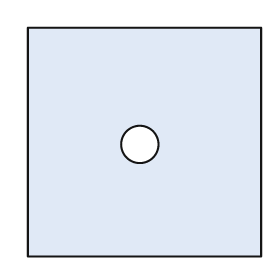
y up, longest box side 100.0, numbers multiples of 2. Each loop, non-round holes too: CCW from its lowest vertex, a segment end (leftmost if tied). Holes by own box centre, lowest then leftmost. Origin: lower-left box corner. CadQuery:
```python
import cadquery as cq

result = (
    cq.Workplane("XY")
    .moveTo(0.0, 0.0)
    .lineTo(100.0, 0.0)
    .lineTo(100.0, 98.0)
    .lineTo(0.0, 98.0)
    .close()
    .moveTo(48.0, 48.0)
    .circle(8.0)
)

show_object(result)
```